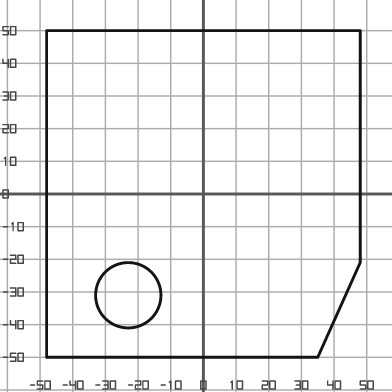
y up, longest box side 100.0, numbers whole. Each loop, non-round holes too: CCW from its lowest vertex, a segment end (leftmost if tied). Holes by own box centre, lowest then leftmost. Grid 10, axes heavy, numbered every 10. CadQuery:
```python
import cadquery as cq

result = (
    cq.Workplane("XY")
    .moveTo(-48.0, -50.0)
    .lineTo(35.0, -50.0)
    .lineTo(48.0, -21.0)
    .lineTo(48.0, 50.0)
    .lineTo(-48.0, 50.0)
    .close()
    .moveTo(-23.0, -31.0)
    .circle(10.0)
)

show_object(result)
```